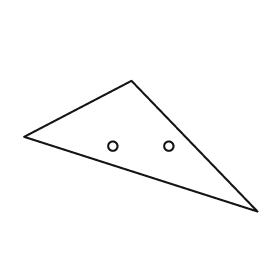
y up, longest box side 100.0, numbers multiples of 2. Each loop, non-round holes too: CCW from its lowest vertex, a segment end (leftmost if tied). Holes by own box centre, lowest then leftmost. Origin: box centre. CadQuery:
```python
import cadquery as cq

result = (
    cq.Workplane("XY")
    .moveTo(50.0, -28.0)
    .lineTo(-4.0, 28.0)
    .lineTo(-50.0, 4.0)
    .close()
    .moveTo(-12.0, 0.0)
    .circle(2.0)
    .moveTo(12.0, 0.0)
    .circle(2.0)
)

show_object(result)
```